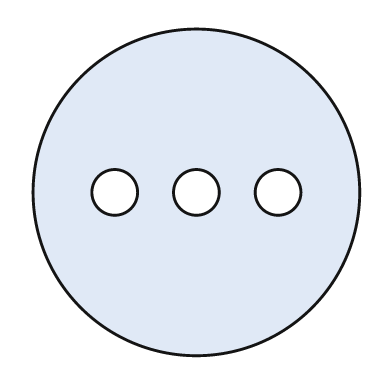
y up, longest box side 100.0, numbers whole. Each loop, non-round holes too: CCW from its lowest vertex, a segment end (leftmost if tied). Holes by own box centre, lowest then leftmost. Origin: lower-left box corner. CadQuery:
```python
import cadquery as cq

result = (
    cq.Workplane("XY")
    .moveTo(50.0, 50.0)
    .circle(50.0)
    .moveTo(25.0, 50.0)
    .circle(7.0)
    .moveTo(50.0, 50.0)
    .circle(7.0)
    .moveTo(75.0, 50.0)
    .circle(7.0)
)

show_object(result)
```